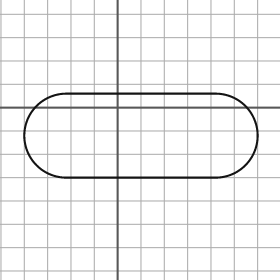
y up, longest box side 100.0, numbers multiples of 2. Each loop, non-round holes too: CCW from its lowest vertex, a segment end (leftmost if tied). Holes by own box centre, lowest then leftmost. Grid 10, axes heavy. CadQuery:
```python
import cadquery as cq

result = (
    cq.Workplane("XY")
    .moveTo(-22.0, -30.0)
    .lineTo(42.0, -30.0)
    .threePointArc((60.0, -12.0), (42.0, 6.0))
    .lineTo(-22.0, 6.0)
    .threePointArc((-40.0, -12.0), (-22.0, -30.0))
    .close()
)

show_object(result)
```